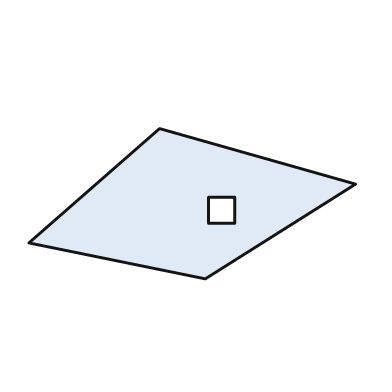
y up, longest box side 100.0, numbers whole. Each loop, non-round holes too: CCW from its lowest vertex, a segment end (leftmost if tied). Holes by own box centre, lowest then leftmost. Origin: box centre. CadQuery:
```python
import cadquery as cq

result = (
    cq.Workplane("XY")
    .moveTo(4.0, -23.0)
    .lineTo(50.0, 6.0)
    .lineTo(-10.0, 23.0)
    .lineTo(-50.0, -12.0)
    .close()
    .moveTo(5.0, -6.0)
    .lineTo(13.0, -6.0)
    .lineTo(13.0, 2.0)
    .lineTo(5.0, 2.0)
    .close()
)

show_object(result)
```